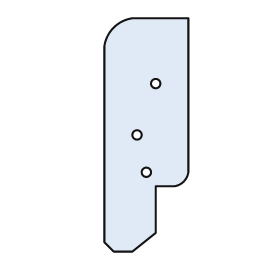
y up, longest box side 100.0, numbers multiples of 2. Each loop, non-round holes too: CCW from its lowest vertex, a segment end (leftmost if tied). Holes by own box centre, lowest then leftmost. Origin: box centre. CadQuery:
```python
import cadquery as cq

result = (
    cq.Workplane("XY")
    .moveTo(-14.0, -50.0)
    .lineTo(-6.0, -50.0)
    .lineTo(4.0, -42.0)
    .lineTo(4.0, -22.0)
    .lineTo(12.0, -22.0)
    .threePointArc((16.0, -20.0), (18.0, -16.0))
    .lineTo(18.0, 50.0)
    .lineTo(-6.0, 50.0)
    .threePointArc((-14.0, 46.0), (-18.0, 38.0))
    .lineTo(-18.0, -46.0)
    .close()
    .moveTo(0.0, -16.0)
    .circle(2.0)
    .moveTo(-4.0, 0.0)
    .circle(2.0)
    .moveTo(4.0, 22.0)
    .circle(2.0)
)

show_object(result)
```